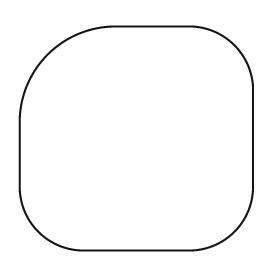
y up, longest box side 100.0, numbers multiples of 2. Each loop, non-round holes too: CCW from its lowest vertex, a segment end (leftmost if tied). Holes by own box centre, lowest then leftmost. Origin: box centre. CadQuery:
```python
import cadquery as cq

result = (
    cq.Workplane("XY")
    .moveTo(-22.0, -48.0)
    .lineTo(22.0, -48.0)
    .threePointArc((42.0, -40.0), (50.0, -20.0))
    .lineTo(50.0, 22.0)
    .threePointArc((42.0, 40.0), (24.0, 48.0))
    .lineTo(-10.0, 48.0)
    .threePointArc((-38.0, 36.0), (-50.0, 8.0))
    .lineTo(-50.0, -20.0)
    .threePointArc((-42.0, -40.0), (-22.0, -48.0))
    .close()
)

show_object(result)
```